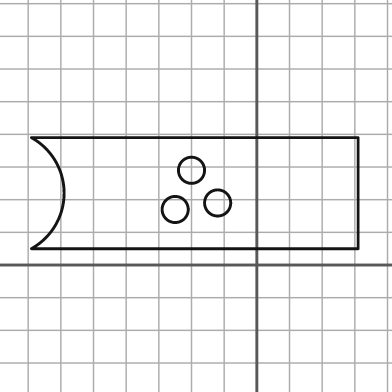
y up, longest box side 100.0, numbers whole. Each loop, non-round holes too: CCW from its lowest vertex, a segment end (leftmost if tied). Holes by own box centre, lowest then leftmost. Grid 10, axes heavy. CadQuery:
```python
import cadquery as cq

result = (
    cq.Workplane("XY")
    .moveTo(-69.0, 5.0)
    .lineTo(31.0, 5.0)
    .lineTo(31.0, 39.0)
    .lineTo(-69.0, 39.0)
    .threePointArc((-59.0, 22.0), (-69.0, 5.0))
    .close()
    .moveTo(-25.0, 17.0)
    .circle(4.0)
    .moveTo(-12.0, 19.0)
    .circle(4.0)
    .moveTo(-20.0, 29.0)
    .circle(4.0)
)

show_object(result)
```